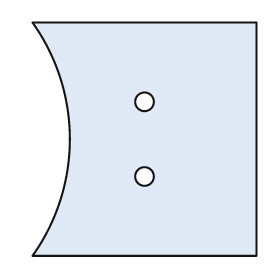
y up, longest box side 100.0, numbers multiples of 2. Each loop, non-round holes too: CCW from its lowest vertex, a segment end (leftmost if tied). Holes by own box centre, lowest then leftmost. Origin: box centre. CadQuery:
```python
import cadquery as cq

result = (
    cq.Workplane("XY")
    .moveTo(-48.0, -50.0)
    .lineTo(48.0, -50.0)
    .lineTo(48.0, 50.0)
    .lineTo(-48.0, 50.0)
    .threePointArc((-32.0, 0.0), (-48.0, -50.0))
    .close()
    .moveTo(0.0, -16.0)
    .circle(4.0)
    .moveTo(0.0, 16.0)
    .circle(4.0)
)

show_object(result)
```